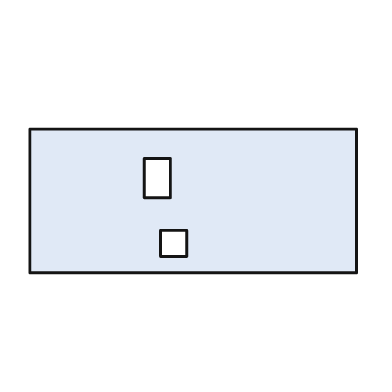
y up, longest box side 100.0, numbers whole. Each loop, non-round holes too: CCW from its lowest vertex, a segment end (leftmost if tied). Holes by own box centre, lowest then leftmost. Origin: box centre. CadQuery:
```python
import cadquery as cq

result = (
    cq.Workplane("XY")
    .moveTo(-50.0, -22.0)
    .lineTo(50.0, -22.0)
    .lineTo(50.0, 22.0)
    .lineTo(-50.0, 22.0)
    .close()
    .moveTo(-10.0, -17.0)
    .lineTo(-2.0, -17.0)
    .lineTo(-2.0, -9.0)
    .lineTo(-10.0, -9.0)
    .close()
    .moveTo(-15.0, 1.0)
    .lineTo(-7.0, 1.0)
    .lineTo(-7.0, 13.0)
    .lineTo(-15.0, 13.0)
    .close()
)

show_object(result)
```